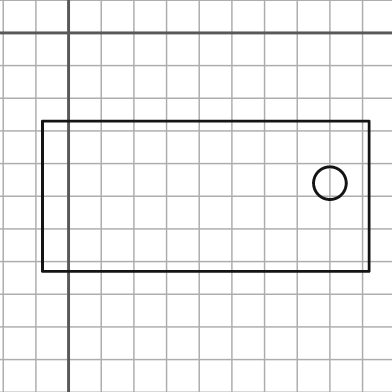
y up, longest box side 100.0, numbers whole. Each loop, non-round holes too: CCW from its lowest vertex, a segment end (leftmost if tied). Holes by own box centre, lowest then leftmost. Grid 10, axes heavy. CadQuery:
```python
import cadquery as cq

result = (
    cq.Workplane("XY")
    .moveTo(-8.0, -73.0)
    .lineTo(92.0, -73.0)
    .lineTo(92.0, -27.0)
    .lineTo(-8.0, -27.0)
    .close()
    .moveTo(80.0, -46.0)
    .circle(5.0)
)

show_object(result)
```